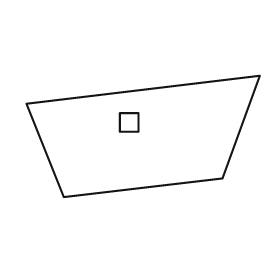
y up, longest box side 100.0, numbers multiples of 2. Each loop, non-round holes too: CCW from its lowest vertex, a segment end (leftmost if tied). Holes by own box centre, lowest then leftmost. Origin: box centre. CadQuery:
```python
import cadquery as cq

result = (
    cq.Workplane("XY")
    .moveTo(-34.0, -26.0)
    .lineTo(34.0, -18.0)
    .lineTo(50.0, 26.0)
    .lineTo(-50.0, 14.0)
    .close()
    .moveTo(-10.0, 2.0)
    .lineTo(-2.0, 2.0)
    .lineTo(-2.0, 10.0)
    .lineTo(-10.0, 10.0)
    .close()
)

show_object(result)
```